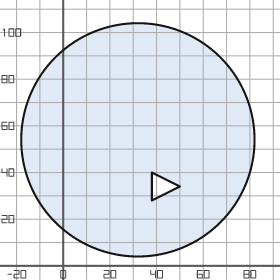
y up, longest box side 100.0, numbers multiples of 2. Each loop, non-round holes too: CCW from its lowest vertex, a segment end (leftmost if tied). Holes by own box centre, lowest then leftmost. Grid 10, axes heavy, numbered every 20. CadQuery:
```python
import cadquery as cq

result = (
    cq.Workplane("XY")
    .moveTo(32.0, 54.0)
    .circle(50.0)
    .moveTo(38.0, 28.0)
    .lineTo(50.0, 34.0)
    .lineTo(38.0, 40.0)
    .close()
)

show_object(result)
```